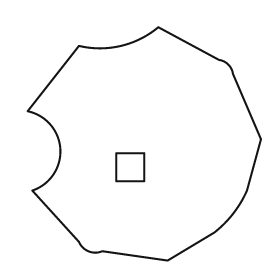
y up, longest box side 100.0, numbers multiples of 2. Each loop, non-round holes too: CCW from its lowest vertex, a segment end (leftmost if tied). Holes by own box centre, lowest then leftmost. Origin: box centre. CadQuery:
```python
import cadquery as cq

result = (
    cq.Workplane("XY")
    .moveTo(10.0, -50.0)
    .lineTo(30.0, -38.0)
    .threePointArc((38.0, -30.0), (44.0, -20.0))
    .lineTo(50.0, 2.0)
    .lineTo(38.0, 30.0)
    .threePointArc((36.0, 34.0), (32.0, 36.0))
    .lineTo(6.0, 50.0)
    .threePointArc((-10.0, 42.0), (-28.0, 42.0))
    .lineTo(-50.0, 14.0)
    .threePointArc((-36.0, -2.0), (-48.0, -20.0))
    .lineTo(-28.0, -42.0)
    .threePointArc((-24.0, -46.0), (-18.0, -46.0))
    .close()
    .moveTo(-12.0, -16.0)
    .lineTo(0.0, -16.0)
    .lineTo(0.0, -4.0)
    .lineTo(-12.0, -4.0)
    .close()
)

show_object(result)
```